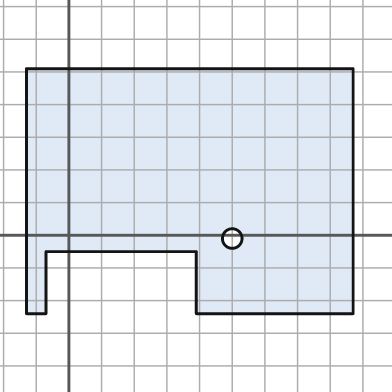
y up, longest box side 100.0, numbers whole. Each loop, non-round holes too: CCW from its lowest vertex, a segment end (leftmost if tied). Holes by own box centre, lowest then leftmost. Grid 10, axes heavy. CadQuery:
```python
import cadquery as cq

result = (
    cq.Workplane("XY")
    .moveTo(-13.0, -24.0)
    .lineTo(-7.0, -24.0)
    .lineTo(-7.0, -5.0)
    .lineTo(39.0, -5.0)
    .lineTo(39.0, -24.0)
    .lineTo(87.0, -24.0)
    .lineTo(87.0, 51.0)
    .lineTo(-13.0, 51.0)
    .close()
    .moveTo(50.0, -1.0)
    .circle(3.0)
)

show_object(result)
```